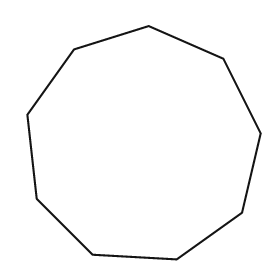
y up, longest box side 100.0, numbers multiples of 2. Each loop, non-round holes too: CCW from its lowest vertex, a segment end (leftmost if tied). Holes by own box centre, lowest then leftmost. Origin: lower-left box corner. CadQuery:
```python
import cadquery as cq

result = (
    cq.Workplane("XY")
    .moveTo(64.0, 0.0)
    .lineTo(92.0, 20.0)
    .lineTo(100.0, 54.0)
    .lineTo(84.0, 86.0)
    .lineTo(52.0, 100.0)
    .lineTo(20.0, 90.0)
    .lineTo(0.0, 62.0)
    .lineTo(4.0, 26.0)
    .lineTo(28.0, 2.0)
    .close()
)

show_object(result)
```